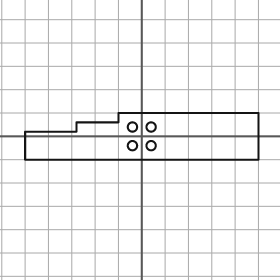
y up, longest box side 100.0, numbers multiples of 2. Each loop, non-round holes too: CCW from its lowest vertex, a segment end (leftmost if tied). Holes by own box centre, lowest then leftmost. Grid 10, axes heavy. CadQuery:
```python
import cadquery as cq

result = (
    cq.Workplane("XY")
    .moveTo(-50.0, -10.0)
    .lineTo(50.0, -10.0)
    .lineTo(50.0, 10.0)
    .lineTo(-10.0, 10.0)
    .lineTo(-10.0, 6.0)
    .lineTo(-28.0, 6.0)
    .lineTo(-28.0, 2.0)
    .lineTo(-50.0, 2.0)
    .close()
    .moveTo(-4.0, -4.0)
    .circle(2.0)
    .moveTo(4.0, -4.0)
    .circle(2.0)
    .moveTo(-4.0, 4.0)
    .circle(2.0)
    .moveTo(4.0, 4.0)
    .circle(2.0)
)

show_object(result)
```